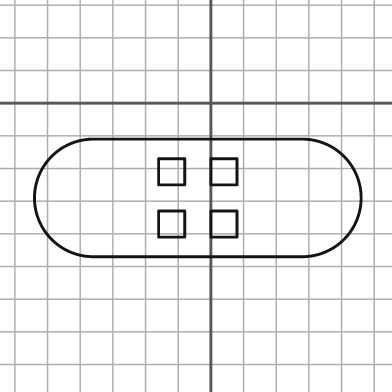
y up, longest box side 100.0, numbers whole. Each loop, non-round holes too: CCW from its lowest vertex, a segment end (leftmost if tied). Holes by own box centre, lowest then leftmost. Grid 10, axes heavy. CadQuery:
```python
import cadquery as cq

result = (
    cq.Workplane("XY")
    .moveTo(-36.0, -47.0)
    .lineTo(28.0, -47.0)
    .threePointArc((46.0, -29.0), (28.0, -11.0))
    .lineTo(-36.0, -11.0)
    .threePointArc((-54.0, -29.0), (-36.0, -47.0))
    .close()
    .moveTo(-16.0, -41.0)
    .lineTo(-8.0, -41.0)
    .lineTo(-8.0, -33.0)
    .lineTo(-16.0, -33.0)
    .close()
    .moveTo(0.0, -41.0)
    .lineTo(8.0, -41.0)
    .lineTo(8.0, -33.0)
    .lineTo(0.0, -33.0)
    .close()
    .moveTo(-16.0, -25.0)
    .lineTo(-8.0, -25.0)
    .lineTo(-8.0, -17.0)
    .lineTo(-16.0, -17.0)
    .close()
    .moveTo(0.0, -25.0)
    .lineTo(8.0, -25.0)
    .lineTo(8.0, -17.0)
    .lineTo(0.0, -17.0)
    .close()
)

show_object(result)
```